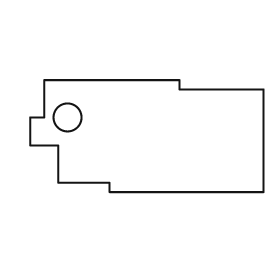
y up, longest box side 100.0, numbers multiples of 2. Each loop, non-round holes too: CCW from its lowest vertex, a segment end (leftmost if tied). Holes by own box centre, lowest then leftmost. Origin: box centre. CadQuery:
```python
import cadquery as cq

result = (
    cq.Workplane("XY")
    .moveTo(-16.0, -24.0)
    .lineTo(50.0, -24.0)
    .lineTo(50.0, 20.0)
    .lineTo(14.0, 20.0)
    .lineTo(14.0, 24.0)
    .lineTo(-44.0, 24.0)
    .lineTo(-44.0, 8.0)
    .lineTo(-50.0, 8.0)
    .lineTo(-50.0, -4.0)
    .lineTo(-38.0, -4.0)
    .lineTo(-38.0, -20.0)
    .lineTo(-16.0, -20.0)
    .close()
    .moveTo(-34.0, 8.0)
    .circle(6.0)
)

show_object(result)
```